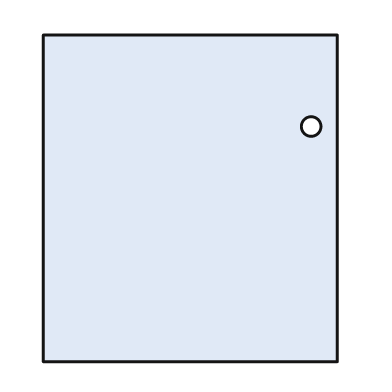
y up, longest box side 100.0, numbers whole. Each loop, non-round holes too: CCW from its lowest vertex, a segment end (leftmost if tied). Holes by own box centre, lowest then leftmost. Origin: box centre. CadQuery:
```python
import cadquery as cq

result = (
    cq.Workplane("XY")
    .moveTo(-45.0, -50.0)
    .lineTo(45.0, -50.0)
    .lineTo(45.0, 50.0)
    .lineTo(-45.0, 50.0)
    .close()
    .moveTo(37.0, 22.0)
    .circle(3.0)
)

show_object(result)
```